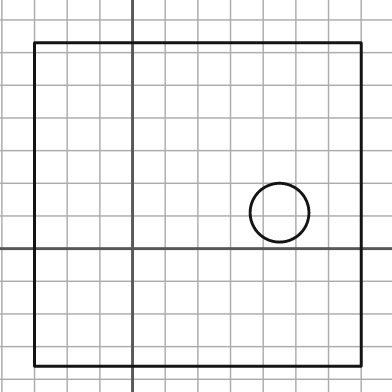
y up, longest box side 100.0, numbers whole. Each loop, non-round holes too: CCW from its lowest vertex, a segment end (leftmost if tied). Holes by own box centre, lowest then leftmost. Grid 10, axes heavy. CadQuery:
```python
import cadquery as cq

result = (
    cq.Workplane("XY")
    .moveTo(-30.0, -36.0)
    .lineTo(70.0, -36.0)
    .lineTo(70.0, 63.0)
    .lineTo(-30.0, 63.0)
    .close()
    .moveTo(45.0, 11.0)
    .circle(9.0)
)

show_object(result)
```